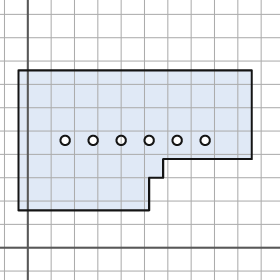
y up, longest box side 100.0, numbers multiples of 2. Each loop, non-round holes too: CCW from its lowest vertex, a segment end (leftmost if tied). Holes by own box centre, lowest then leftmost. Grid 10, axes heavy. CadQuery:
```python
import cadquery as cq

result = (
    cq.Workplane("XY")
    .moveTo(-4.0, 16.0)
    .lineTo(52.0, 16.0)
    .lineTo(52.0, 30.0)
    .lineTo(58.0, 30.0)
    .lineTo(58.0, 38.0)
    .lineTo(96.0, 38.0)
    .lineTo(96.0, 76.0)
    .lineTo(-4.0, 76.0)
    .close()
    .moveTo(16.0, 46.0)
    .circle(2.0)
    .moveTo(28.0, 46.0)
    .circle(2.0)
    .moveTo(40.0, 46.0)
    .circle(2.0)
    .moveTo(52.0, 46.0)
    .circle(2.0)
    .moveTo(64.0, 46.0)
    .circle(2.0)
    .moveTo(76.0, 46.0)
    .circle(2.0)
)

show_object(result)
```